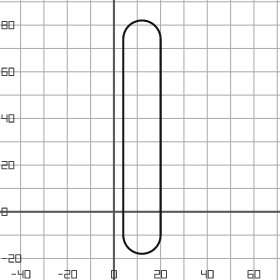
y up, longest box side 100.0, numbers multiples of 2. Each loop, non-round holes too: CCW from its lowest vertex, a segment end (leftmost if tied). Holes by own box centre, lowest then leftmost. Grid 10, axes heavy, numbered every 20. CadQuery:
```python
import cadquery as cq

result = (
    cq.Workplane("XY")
    .moveTo(4.0, -10.0)
    .threePointArc((12.0, -18.0), (20.0, -10.0))
    .lineTo(20.0, 74.0)
    .threePointArc((12.0, 82.0), (4.0, 74.0))
    .close()
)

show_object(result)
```